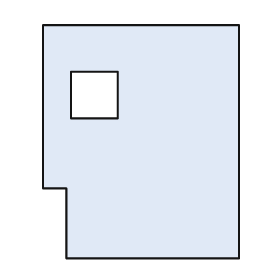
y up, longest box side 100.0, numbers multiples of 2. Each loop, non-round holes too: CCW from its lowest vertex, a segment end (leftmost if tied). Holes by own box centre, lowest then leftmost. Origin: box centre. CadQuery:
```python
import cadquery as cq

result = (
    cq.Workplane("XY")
    .moveTo(-32.0, -50.0)
    .lineTo(42.0, -50.0)
    .lineTo(42.0, 50.0)
    .lineTo(-42.0, 50.0)
    .lineTo(-42.0, -20.0)
    .lineTo(-32.0, -20.0)
    .close()
    .moveTo(-30.0, 10.0)
    .lineTo(-10.0, 10.0)
    .lineTo(-10.0, 30.0)
    .lineTo(-30.0, 30.0)
    .close()
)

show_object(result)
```